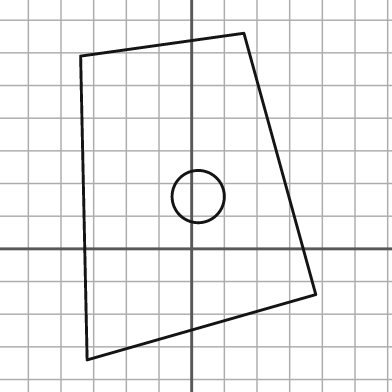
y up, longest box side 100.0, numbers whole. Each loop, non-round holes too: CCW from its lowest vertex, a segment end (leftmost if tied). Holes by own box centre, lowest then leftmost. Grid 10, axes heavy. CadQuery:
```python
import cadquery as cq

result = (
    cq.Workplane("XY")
    .moveTo(-32.0, -34.0)
    .lineTo(38.0, -14.0)
    .lineTo(16.0, 66.0)
    .lineTo(-34.0, 59.0)
    .close()
    .moveTo(2.0, 16.0)
    .circle(8.0)
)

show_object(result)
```